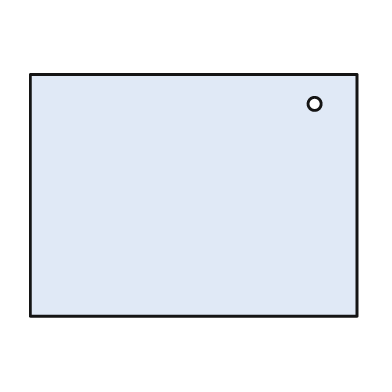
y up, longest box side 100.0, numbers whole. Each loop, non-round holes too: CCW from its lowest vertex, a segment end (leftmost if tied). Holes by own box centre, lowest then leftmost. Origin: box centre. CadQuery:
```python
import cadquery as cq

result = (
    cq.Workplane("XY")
    .moveTo(-50.0, -37.0)
    .lineTo(50.0, -37.0)
    .lineTo(50.0, 37.0)
    .lineTo(-50.0, 37.0)
    .close()
    .moveTo(37.0, 28.0)
    .circle(2.0)
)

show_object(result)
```